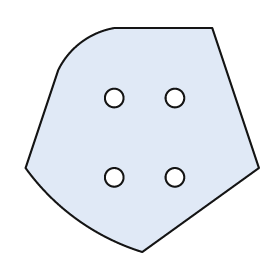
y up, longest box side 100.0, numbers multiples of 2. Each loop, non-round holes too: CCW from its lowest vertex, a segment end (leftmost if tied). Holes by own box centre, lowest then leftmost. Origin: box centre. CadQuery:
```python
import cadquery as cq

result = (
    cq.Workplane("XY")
    .moveTo(0.0, -48.0)
    .lineTo(50.0, -12.0)
    .lineTo(30.0, 48.0)
    .lineTo(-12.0, 48.0)
    .threePointArc((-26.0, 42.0), (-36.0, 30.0))
    .lineTo(-50.0, -12.0)
    .threePointArc((-28.0, -34.0), (0.0, -48.0))
    .close()
    .moveTo(-12.0, -16.0)
    .circle(4.0)
    .moveTo(14.0, -16.0)
    .circle(4.0)
    .moveTo(-12.0, 18.0)
    .circle(4.0)
    .moveTo(14.0, 18.0)
    .circle(4.0)
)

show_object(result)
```